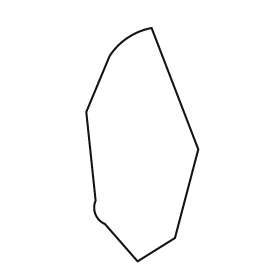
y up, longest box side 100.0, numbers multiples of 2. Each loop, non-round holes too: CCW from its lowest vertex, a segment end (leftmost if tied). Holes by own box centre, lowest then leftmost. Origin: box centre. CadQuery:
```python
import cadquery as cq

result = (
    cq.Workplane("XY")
    .moveTo(-2.0, -50.0)
    .lineTo(14.0, -40.0)
    .lineTo(24.0, -2.0)
    .lineTo(4.0, 50.0)
    .threePointArc((-6.0, 46.0), (-14.0, 38.0))
    .lineTo(-24.0, 14.0)
    .lineTo(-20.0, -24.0)
    .threePointArc((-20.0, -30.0), (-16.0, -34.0))
    .close()
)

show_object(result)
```